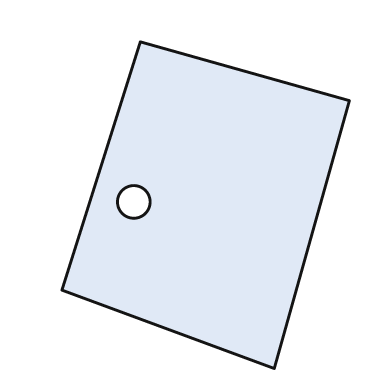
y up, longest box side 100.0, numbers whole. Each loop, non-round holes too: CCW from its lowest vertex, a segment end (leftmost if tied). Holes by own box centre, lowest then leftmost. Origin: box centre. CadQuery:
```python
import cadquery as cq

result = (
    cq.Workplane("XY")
    .moveTo(21.0, -50.0)
    .lineTo(44.0, 32.0)
    .lineTo(-20.0, 50.0)
    .lineTo(-44.0, -26.0)
    .close()
    .moveTo(-22.0, 1.0)
    .circle(5.0)
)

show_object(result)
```